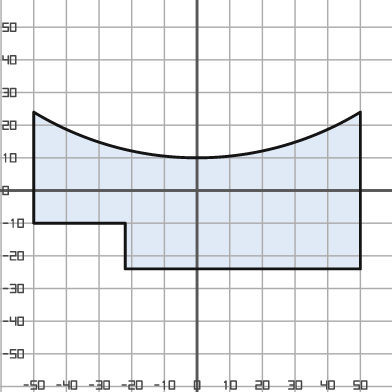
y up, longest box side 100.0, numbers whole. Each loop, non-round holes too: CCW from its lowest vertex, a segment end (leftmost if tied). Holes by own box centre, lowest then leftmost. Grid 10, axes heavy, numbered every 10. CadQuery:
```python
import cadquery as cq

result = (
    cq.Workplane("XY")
    .moveTo(-22.0, -24.0)
    .lineTo(50.0, -24.0)
    .lineTo(50.0, 24.0)
    .threePointArc((0.0, 10.0), (-50.0, 24.0))
    .lineTo(-50.0, -10.0)
    .lineTo(-22.0, -10.0)
    .close()
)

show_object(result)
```